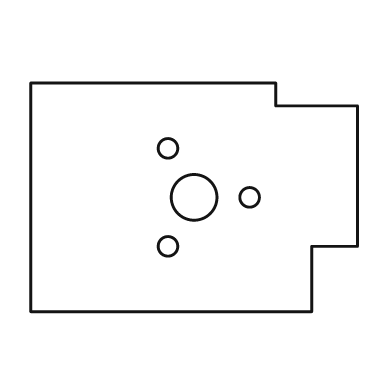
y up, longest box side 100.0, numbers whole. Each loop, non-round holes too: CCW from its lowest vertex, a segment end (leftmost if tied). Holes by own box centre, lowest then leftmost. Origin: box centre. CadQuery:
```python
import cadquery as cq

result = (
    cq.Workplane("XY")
    .moveTo(-50.0, -35.0)
    .lineTo(36.0, -35.0)
    .lineTo(36.0, -15.0)
    .lineTo(50.0, -15.0)
    .lineTo(50.0, 28.0)
    .lineTo(25.0, 28.0)
    .lineTo(25.0, 35.0)
    .lineTo(-50.0, 35.0)
    .close()
    .moveTo(-8.0, -15.0)
    .circle(3.0)
    .moveTo(0.0, 0.0)
    .circle(7.0)
    .moveTo(17.0, 0.0)
    .circle(3.0)
    .moveTo(-8.0, 15.0)
    .circle(3.0)
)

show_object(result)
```